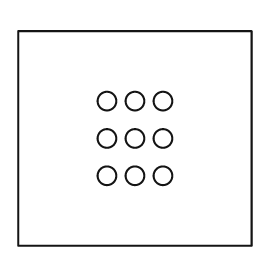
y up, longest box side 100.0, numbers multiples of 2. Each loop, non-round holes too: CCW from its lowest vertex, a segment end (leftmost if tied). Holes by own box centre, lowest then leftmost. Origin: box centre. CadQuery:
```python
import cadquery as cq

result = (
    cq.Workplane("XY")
    .moveTo(-50.0, -46.0)
    .lineTo(50.0, -46.0)
    .lineTo(50.0, 46.0)
    .lineTo(-50.0, 46.0)
    .close()
    .moveTo(-12.0, -16.0)
    .circle(4.0)
    .moveTo(0.0, -16.0)
    .circle(4.0)
    .moveTo(12.0, -16.0)
    .circle(4.0)
    .moveTo(-12.0, 0.0)
    .circle(4.0)
    .moveTo(0.0, 0.0)
    .circle(4.0)
    .moveTo(12.0, 0.0)
    .circle(4.0)
    .moveTo(-12.0, 16.0)
    .circle(4.0)
    .moveTo(0.0, 16.0)
    .circle(4.0)
    .moveTo(12.0, 16.0)
    .circle(4.0)
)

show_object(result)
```